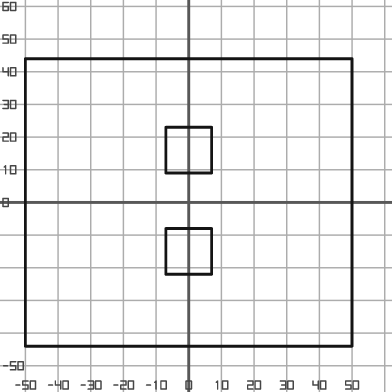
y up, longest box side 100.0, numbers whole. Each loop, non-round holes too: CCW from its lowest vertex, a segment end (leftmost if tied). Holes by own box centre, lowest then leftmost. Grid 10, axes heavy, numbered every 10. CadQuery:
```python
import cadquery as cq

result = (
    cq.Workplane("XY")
    .moveTo(-50.0, -44.0)
    .lineTo(50.0, -44.0)
    .lineTo(50.0, 44.0)
    .lineTo(-50.0, 44.0)
    .close()
    .moveTo(-7.0, -22.0)
    .lineTo(7.0, -22.0)
    .lineTo(7.0, -8.0)
    .lineTo(-7.0, -8.0)
    .close()
    .moveTo(-7.0, 9.0)
    .lineTo(7.0, 9.0)
    .lineTo(7.0, 23.0)
    .lineTo(-7.0, 23.0)
    .close()
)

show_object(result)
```